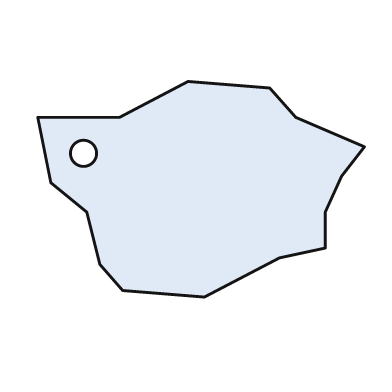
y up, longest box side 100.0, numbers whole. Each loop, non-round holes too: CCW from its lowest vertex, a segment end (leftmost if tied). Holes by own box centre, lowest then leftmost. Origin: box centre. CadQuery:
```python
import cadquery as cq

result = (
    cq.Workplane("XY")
    .moveTo(1.0, -33.0)
    .lineTo(24.0, -21.0)
    .lineTo(38.0, -18.0)
    .lineTo(38.0, -7.0)
    .lineTo(43.0, 4.0)
    .lineTo(50.0, 13.0)
    .lineTo(29.0, 22.0)
    .lineTo(21.0, 31.0)
    .lineTo(-4.0, 33.0)
    .lineTo(-25.0, 22.0)
    .lineTo(-50.0, 22.0)
    .lineTo(-46.0, 2.0)
    .lineTo(-35.0, -7.0)
    .lineTo(-31.0, -23.0)
    .lineTo(-24.0, -31.0)
    .close()
    .moveTo(-36.0, 11.0)
    .circle(4.0)
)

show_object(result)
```